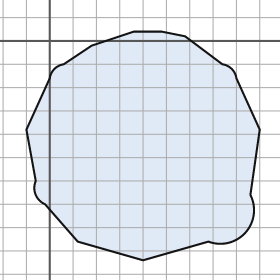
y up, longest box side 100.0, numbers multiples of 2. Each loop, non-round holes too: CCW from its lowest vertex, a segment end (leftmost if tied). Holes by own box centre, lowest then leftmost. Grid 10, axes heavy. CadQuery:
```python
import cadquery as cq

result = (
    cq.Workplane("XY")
    .moveTo(40.0, -94.0)
    .lineTo(68.0, -86.0)
    .threePointArc((84.0, -82.0), (86.0, -66.0))
    .lineTo(90.0, -38.0)
    .lineTo(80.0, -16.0)
    .threePointArc((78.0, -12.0), (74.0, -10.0))
    .lineTo(58.0, 2.0)
    .lineTo(48.0, 4.0)
    .lineTo(36.0, 4.0)
    .lineTo(18.0, -2.0)
    .lineTo(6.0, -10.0)
    .threePointArc((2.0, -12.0), (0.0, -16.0))
    .lineTo(-10.0, -38.0)
    .lineTo(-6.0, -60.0)
    .threePointArc((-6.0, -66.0), (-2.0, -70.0))
    .lineTo(12.0, -86.0)
    .close()
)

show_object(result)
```